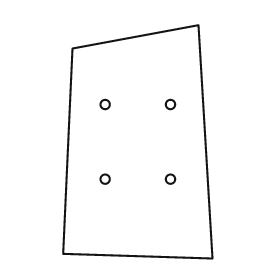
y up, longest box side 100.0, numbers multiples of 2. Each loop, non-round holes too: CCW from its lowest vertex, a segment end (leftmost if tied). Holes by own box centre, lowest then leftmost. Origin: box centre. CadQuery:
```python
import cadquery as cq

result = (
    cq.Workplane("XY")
    .moveTo(32.0, -50.0)
    .lineTo(26.0, 50.0)
    .lineTo(-28.0, 40.0)
    .lineTo(-32.0, -48.0)
    .close()
    .moveTo(-14.0, -16.0)
    .circle(2.0)
    .moveTo(14.0, -16.0)
    .circle(2.0)
    .moveTo(-14.0, 16.0)
    .circle(2.0)
    .moveTo(14.0, 16.0)
    .circle(2.0)
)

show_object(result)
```